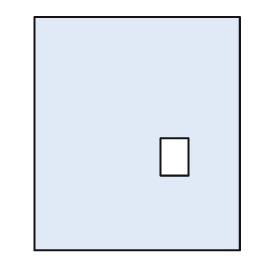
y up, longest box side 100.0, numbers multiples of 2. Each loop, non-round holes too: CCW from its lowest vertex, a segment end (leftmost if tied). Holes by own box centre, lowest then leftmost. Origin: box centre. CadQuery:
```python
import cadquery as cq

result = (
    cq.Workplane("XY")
    .moveTo(-44.0, -50.0)
    .lineTo(44.0, -50.0)
    .lineTo(44.0, 50.0)
    .lineTo(-44.0, 50.0)
    .close()
    .moveTo(10.0, -18.0)
    .lineTo(22.0, -18.0)
    .lineTo(22.0, -2.0)
    .lineTo(10.0, -2.0)
    .close()
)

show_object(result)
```